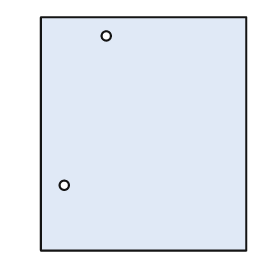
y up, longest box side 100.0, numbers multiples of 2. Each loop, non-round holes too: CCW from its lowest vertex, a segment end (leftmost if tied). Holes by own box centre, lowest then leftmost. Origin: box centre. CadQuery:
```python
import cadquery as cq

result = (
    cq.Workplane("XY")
    .moveTo(-44.0, -50.0)
    .lineTo(44.0, -50.0)
    .lineTo(44.0, 50.0)
    .lineTo(-44.0, 50.0)
    .close()
    .moveTo(-34.0, -22.0)
    .circle(2.0)
    .moveTo(-16.0, 42.0)
    .circle(2.0)
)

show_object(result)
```